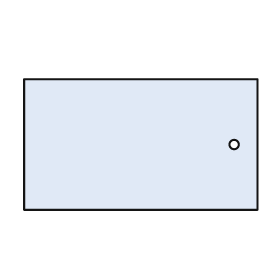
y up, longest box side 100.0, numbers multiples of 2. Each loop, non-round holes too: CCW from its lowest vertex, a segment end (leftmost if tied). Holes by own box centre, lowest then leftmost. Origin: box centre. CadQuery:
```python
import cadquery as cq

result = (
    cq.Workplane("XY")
    .moveTo(-50.0, -28.0)
    .lineTo(50.0, -28.0)
    .lineTo(50.0, 28.0)
    .lineTo(-50.0, 28.0)
    .close()
    .moveTo(40.0, 0.0)
    .circle(2.0)
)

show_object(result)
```